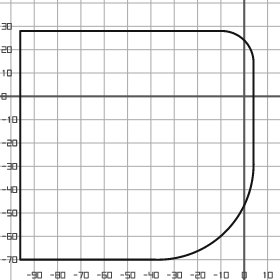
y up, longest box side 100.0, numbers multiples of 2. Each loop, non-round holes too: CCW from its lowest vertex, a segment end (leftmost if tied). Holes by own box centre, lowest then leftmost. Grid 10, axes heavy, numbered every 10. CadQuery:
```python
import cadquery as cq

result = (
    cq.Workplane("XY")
    .moveTo(-96.0, -70.0)
    .lineTo(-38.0, -70.0)
    .threePointArc((-8.0, -58.0), (4.0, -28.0))
    .lineTo(4.0, 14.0)
    .threePointArc((0.0, 24.0), (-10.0, 28.0))
    .lineTo(-96.0, 28.0)
    .close()
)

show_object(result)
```